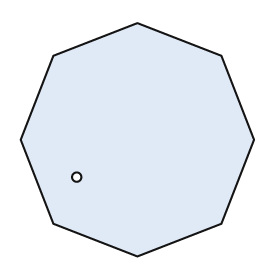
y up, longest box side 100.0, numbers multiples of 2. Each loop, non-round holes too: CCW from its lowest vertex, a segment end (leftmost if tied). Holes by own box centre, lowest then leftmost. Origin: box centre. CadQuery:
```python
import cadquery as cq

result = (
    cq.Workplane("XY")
    .moveTo(0.0, -50.0)
    .lineTo(36.0, -36.0)
    .lineTo(50.0, 0.0)
    .lineTo(36.0, 36.0)
    .lineTo(0.0, 50.0)
    .lineTo(-36.0, 36.0)
    .lineTo(-50.0, 0.0)
    .lineTo(-36.0, -36.0)
    .close()
    .moveTo(-26.0, -16.0)
    .circle(2.0)
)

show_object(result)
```